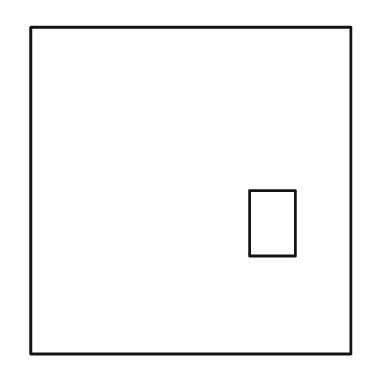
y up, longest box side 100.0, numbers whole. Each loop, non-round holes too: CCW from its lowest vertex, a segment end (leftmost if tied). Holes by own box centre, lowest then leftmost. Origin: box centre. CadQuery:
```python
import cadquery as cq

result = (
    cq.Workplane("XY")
    .moveTo(-49.0, -50.0)
    .lineTo(49.0, -50.0)
    .lineTo(49.0, 50.0)
    .lineTo(-49.0, 50.0)
    .close()
    .moveTo(18.0, -20.0)
    .lineTo(32.0, -20.0)
    .lineTo(32.0, 0.0)
    .lineTo(18.0, 0.0)
    .close()
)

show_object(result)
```